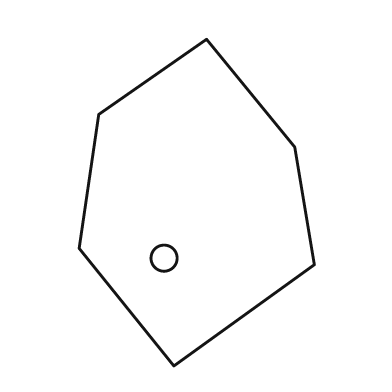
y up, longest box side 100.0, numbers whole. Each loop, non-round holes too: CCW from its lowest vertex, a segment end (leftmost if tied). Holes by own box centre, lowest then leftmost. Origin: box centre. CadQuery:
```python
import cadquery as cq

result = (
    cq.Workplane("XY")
    .moveTo(-7.0, -50.0)
    .lineTo(36.0, -19.0)
    .lineTo(30.0, 17.0)
    .lineTo(3.0, 50.0)
    .lineTo(-30.0, 27.0)
    .lineTo(-36.0, -14.0)
    .close()
    .moveTo(-10.0, -17.0)
    .circle(4.0)
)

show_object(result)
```